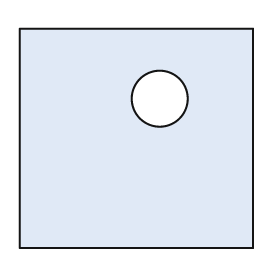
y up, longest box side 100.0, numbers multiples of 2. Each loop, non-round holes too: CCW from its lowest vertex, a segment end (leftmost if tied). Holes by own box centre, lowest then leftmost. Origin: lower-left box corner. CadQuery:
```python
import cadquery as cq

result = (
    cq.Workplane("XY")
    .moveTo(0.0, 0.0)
    .lineTo(100.0, 0.0)
    .lineTo(100.0, 94.0)
    .lineTo(0.0, 94.0)
    .close()
    .moveTo(60.0, 64.0)
    .circle(12.0)
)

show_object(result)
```